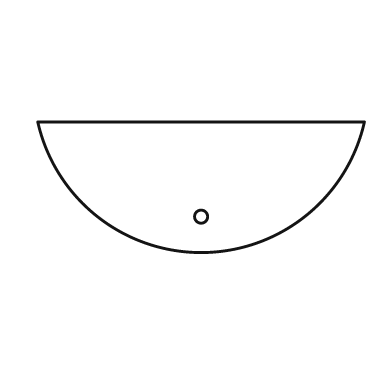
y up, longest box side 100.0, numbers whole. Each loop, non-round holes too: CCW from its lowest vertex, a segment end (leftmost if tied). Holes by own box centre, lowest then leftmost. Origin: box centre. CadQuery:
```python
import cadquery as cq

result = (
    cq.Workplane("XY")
    .moveTo(-50.0, 20.0)
    .threePointArc((0.0, -20.0), (50.0, 20.0))
    .close()
    .moveTo(0.0, -9.0)
    .circle(2.0)
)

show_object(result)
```